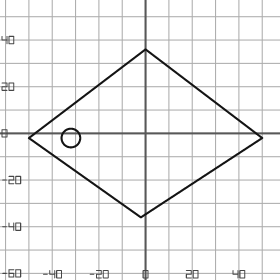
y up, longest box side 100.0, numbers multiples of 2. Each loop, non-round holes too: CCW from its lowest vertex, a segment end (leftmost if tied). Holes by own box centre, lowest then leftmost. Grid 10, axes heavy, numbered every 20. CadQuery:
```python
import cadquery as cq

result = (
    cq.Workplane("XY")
    .moveTo(-2.0, -36.0)
    .lineTo(50.0, -2.0)
    .lineTo(0.0, 36.0)
    .lineTo(-50.0, -2.0)
    .close()
    .moveTo(-32.0, -2.0)
    .circle(4.0)
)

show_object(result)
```